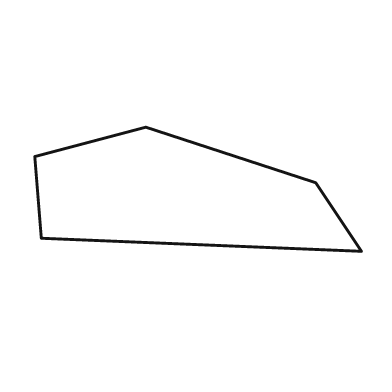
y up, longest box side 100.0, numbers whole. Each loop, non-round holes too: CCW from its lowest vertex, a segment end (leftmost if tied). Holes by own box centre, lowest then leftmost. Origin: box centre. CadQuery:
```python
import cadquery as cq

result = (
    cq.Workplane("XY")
    .moveTo(50.0, -19.0)
    .lineTo(36.0, 2.0)
    .lineTo(-16.0, 19.0)
    .lineTo(-50.0, 10.0)
    .lineTo(-48.0, -15.0)
    .close()
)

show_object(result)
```